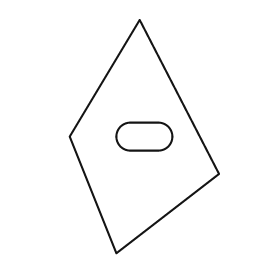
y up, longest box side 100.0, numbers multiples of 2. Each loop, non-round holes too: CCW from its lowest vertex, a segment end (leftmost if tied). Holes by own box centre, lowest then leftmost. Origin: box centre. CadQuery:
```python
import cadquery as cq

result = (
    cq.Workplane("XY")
    .moveTo(-12.0, -50.0)
    .lineTo(32.0, -16.0)
    .lineTo(-2.0, 50.0)
    .lineTo(-32.0, 0.0)
    .close()
    .moveTo(-6.0, -6.0)
    .lineTo(6.0, -6.0)
    .threePointArc((12.0, 0.0), (6.0, 6.0))
    .lineTo(-6.0, 6.0)
    .threePointArc((-12.0, 0.0), (-6.0, -6.0))
    .close()
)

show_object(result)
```